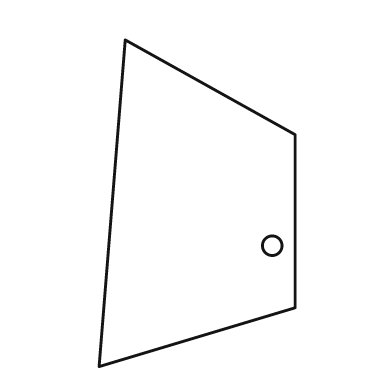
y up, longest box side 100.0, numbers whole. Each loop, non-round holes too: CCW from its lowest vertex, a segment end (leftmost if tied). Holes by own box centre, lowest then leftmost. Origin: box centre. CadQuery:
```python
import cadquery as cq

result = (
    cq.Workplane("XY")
    .moveTo(-30.0, -50.0)
    .lineTo(30.0, -32.0)
    .lineTo(30.0, 21.0)
    .lineTo(-22.0, 50.0)
    .close()
    .moveTo(23.0, -13.0)
    .circle(3.0)
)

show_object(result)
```